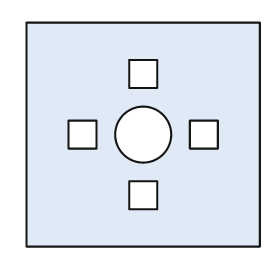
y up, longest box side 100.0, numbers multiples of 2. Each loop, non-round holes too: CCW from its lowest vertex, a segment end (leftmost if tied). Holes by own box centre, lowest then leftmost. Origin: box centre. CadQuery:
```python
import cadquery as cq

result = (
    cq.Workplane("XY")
    .moveTo(-50.0, -48.0)
    .lineTo(50.0, -48.0)
    .lineTo(50.0, 48.0)
    .lineTo(-50.0, 48.0)
    .close()
    .moveTo(-6.0, -32.0)
    .lineTo(6.0, -32.0)
    .lineTo(6.0, -20.0)
    .lineTo(-6.0, -20.0)
    .close()
    .moveTo(-32.0, -6.0)
    .lineTo(-20.0, -6.0)
    .lineTo(-20.0, 6.0)
    .lineTo(-32.0, 6.0)
    .close()
    .moveTo(0.0, 0.0)
    .circle(12.0)
    .moveTo(20.0, -6.0)
    .lineTo(32.0, -6.0)
    .lineTo(32.0, 6.0)
    .lineTo(20.0, 6.0)
    .close()
    .moveTo(-6.0, 20.0)
    .lineTo(6.0, 20.0)
    .lineTo(6.0, 32.0)
    .lineTo(-6.0, 32.0)
    .close()
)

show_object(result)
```